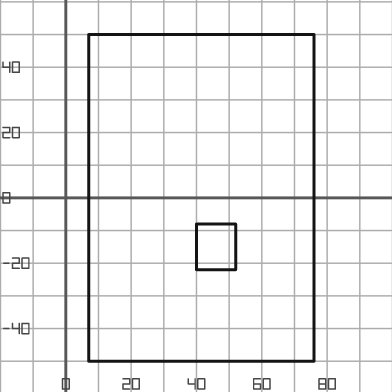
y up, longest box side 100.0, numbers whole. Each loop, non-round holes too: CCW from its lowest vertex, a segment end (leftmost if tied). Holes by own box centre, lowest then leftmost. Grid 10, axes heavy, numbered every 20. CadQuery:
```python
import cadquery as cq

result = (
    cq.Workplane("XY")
    .moveTo(7.0, -50.0)
    .lineTo(76.0, -50.0)
    .lineTo(76.0, 50.0)
    .lineTo(7.0, 50.0)
    .close()
    .moveTo(40.0, -22.0)
    .lineTo(52.0, -22.0)
    .lineTo(52.0, -8.0)
    .lineTo(40.0, -8.0)
    .close()
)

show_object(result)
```